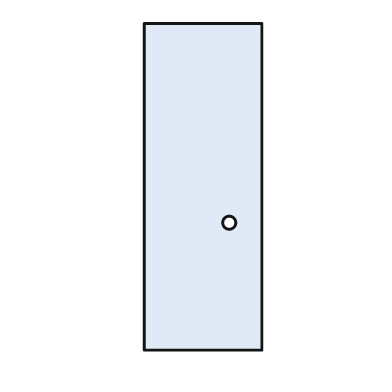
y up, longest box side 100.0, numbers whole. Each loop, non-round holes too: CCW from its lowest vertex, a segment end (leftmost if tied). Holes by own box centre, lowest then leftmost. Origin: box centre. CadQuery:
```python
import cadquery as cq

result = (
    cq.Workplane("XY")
    .moveTo(-18.0, -50.0)
    .lineTo(18.0, -50.0)
    .lineTo(18.0, 50.0)
    .lineTo(-18.0, 50.0)
    .close()
    .moveTo(8.0, -11.0)
    .circle(2.0)
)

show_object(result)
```